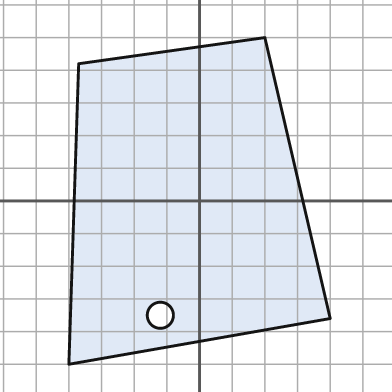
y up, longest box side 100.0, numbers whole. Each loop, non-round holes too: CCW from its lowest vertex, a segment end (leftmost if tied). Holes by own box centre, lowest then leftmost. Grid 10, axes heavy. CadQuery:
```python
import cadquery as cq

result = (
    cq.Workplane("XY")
    .moveTo(-40.0, -50.0)
    .lineTo(40.0, -36.0)
    .lineTo(20.0, 50.0)
    .lineTo(-37.0, 42.0)
    .close()
    .moveTo(-12.0, -35.0)
    .circle(4.0)
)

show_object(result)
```